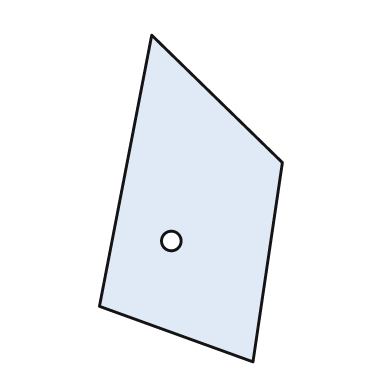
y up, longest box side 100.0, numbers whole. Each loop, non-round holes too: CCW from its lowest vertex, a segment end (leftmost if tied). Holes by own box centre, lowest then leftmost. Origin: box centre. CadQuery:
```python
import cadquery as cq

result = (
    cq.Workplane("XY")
    .moveTo(19.0, -50.0)
    .lineTo(28.0, 11.0)
    .lineTo(-12.0, 50.0)
    .lineTo(-28.0, -33.0)
    .close()
    .moveTo(-6.0, -13.0)
    .circle(3.0)
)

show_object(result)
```